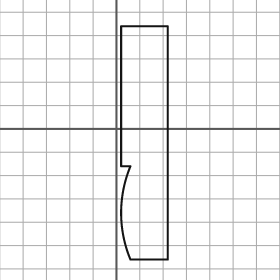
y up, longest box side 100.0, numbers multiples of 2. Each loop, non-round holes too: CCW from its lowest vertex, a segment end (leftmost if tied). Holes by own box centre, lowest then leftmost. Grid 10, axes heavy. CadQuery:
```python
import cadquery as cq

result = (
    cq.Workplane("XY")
    .moveTo(6.0, -56.0)
    .lineTo(22.0, -56.0)
    .lineTo(22.0, 44.0)
    .lineTo(2.0, 44.0)
    .lineTo(2.0, -16.0)
    .lineTo(6.0, -16.0)
    .threePointArc((2.0, -36.0), (6.0, -56.0))
    .close()
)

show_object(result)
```